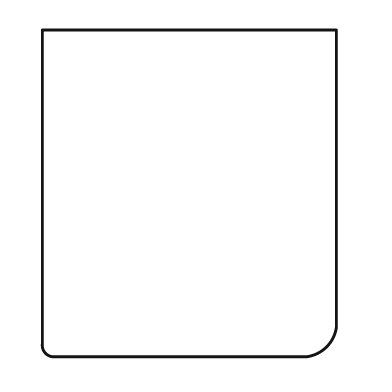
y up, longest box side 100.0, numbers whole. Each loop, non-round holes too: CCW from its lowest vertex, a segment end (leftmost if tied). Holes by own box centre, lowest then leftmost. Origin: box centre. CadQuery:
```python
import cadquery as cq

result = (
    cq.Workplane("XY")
    .moveTo(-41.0, -50.0)
    .lineTo(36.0, -50.0)
    .threePointArc((42.0, -47.0), (45.0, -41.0))
    .lineTo(45.0, 50.0)
    .lineTo(-45.0, 50.0)
    .lineTo(-45.0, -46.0)
    .threePointArc((-44.0, -49.0), (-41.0, -50.0))
    .close()
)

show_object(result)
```